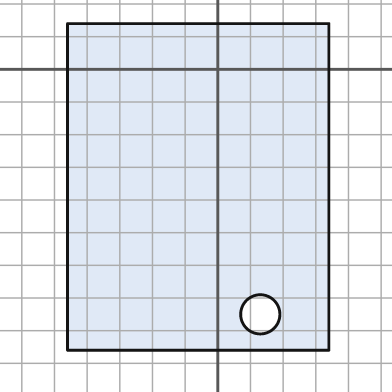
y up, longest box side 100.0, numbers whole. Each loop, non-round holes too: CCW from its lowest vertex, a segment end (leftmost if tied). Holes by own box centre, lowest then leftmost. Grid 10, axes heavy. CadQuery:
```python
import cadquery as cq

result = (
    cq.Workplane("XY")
    .moveTo(-46.0, -86.0)
    .lineTo(34.0, -86.0)
    .lineTo(34.0, 14.0)
    .lineTo(-46.0, 14.0)
    .close()
    .moveTo(13.0, -75.0)
    .circle(6.0)
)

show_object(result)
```